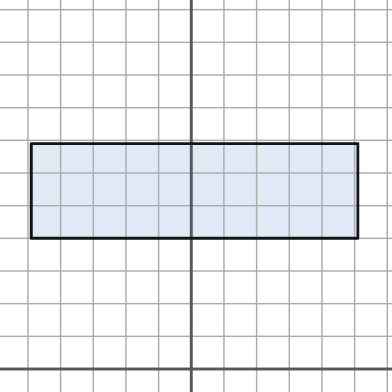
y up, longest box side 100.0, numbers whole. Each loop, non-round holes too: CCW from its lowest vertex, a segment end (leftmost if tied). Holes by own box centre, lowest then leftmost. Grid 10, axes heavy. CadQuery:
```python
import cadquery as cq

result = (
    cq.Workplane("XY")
    .moveTo(-49.0, 40.0)
    .lineTo(51.0, 40.0)
    .lineTo(51.0, 69.0)
    .lineTo(-49.0, 69.0)
    .close()
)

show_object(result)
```